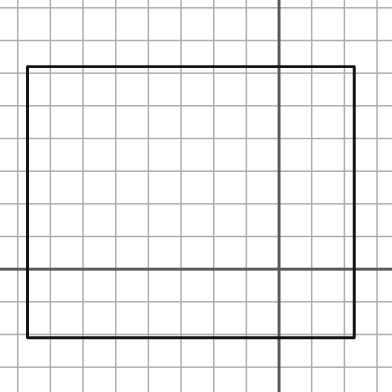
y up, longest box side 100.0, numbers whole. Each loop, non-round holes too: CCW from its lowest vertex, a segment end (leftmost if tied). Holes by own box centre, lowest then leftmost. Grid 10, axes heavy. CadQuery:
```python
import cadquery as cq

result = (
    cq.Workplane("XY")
    .moveTo(-77.0, -21.0)
    .lineTo(23.0, -21.0)
    .lineTo(23.0, 62.0)
    .lineTo(-77.0, 62.0)
    .close()
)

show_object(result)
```